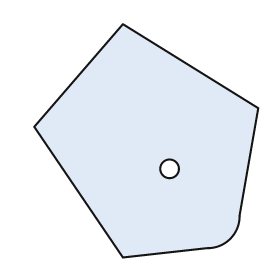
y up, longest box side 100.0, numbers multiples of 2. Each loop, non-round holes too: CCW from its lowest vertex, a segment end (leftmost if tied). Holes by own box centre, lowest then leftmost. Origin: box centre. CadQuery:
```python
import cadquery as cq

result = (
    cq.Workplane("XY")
    .moveTo(-10.0, -50.0)
    .lineTo(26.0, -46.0)
    .threePointArc((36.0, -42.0), (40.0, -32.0))
    .lineTo(48.0, 14.0)
    .lineTo(-10.0, 50.0)
    .lineTo(-48.0, 6.0)
    .close()
    .moveTo(10.0, -12.0)
    .circle(4.0)
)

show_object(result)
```